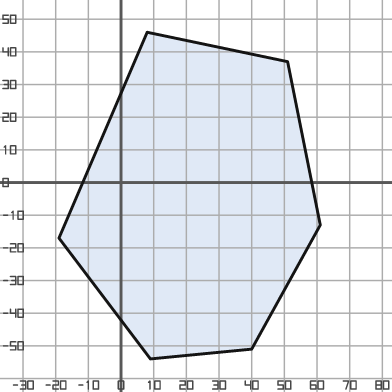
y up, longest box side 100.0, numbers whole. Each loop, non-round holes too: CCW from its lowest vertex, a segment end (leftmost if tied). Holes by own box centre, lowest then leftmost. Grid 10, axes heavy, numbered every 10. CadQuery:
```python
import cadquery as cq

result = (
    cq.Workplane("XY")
    .moveTo(9.0, -54.0)
    .lineTo(40.0, -51.0)
    .lineTo(61.0, -13.0)
    .lineTo(51.0, 37.0)
    .lineTo(8.0, 46.0)
    .lineTo(-19.0, -17.0)
    .close()
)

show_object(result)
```